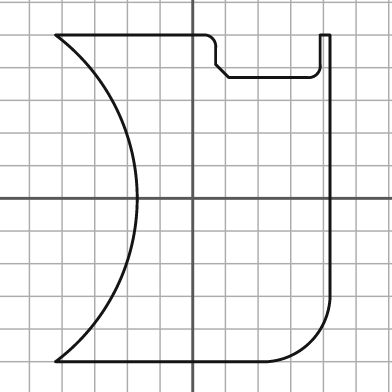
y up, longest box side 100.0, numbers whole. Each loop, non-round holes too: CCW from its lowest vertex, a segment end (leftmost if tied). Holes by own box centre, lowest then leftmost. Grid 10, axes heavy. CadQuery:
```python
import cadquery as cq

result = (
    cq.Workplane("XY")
    .moveTo(-42.0, -50.0)
    .lineTo(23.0, -50.0)
    .threePointArc((36.0, -44.0), (42.0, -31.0))
    .lineTo(42.0, 50.0)
    .lineTo(39.0, 50.0)
    .lineTo(39.0, 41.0)
    .threePointArc((38.0, 38.0), (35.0, 37.0))
    .lineTo(11.0, 37.0)
    .lineTo(7.0, 41.0)
    .lineTo(7.0, 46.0)
    .threePointArc((6.0, 49.0), (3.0, 50.0))
    .lineTo(-42.0, 50.0)
    .threePointArc((-17.0, 0.0), (-42.0, -50.0))
    .close()
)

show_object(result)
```